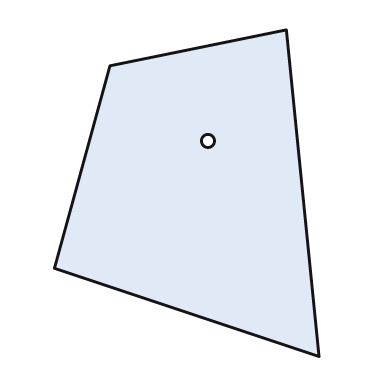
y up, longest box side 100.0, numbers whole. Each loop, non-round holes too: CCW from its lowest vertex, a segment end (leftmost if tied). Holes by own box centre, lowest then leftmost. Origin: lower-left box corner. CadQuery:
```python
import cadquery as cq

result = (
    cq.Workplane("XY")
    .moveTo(81.0, 0.0)
    .lineTo(71.0, 100.0)
    .lineTo(17.0, 89.0)
    .lineTo(0.0, 27.0)
    .close()
    .moveTo(47.0, 66.0)
    .circle(2.0)
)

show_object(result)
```